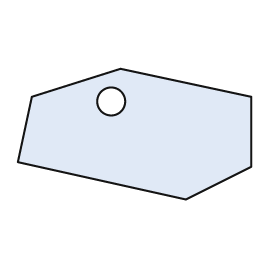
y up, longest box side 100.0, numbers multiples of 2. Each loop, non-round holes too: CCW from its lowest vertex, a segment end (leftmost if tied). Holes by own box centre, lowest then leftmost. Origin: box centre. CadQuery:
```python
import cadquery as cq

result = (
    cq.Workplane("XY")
    .moveTo(22.0, -28.0)
    .lineTo(50.0, -14.0)
    .lineTo(50.0, 16.0)
    .lineTo(-6.0, 28.0)
    .lineTo(-44.0, 16.0)
    .lineTo(-50.0, -12.0)
    .close()
    .moveTo(-10.0, 14.0)
    .circle(6.0)
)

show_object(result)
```